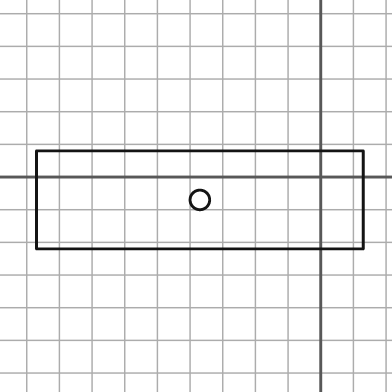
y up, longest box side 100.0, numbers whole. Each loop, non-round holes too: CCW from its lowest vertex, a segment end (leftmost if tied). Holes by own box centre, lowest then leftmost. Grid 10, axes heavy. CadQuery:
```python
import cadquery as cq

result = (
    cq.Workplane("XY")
    .moveTo(-87.0, -22.0)
    .lineTo(13.0, -22.0)
    .lineTo(13.0, 8.0)
    .lineTo(-87.0, 8.0)
    .close()
    .moveTo(-37.0, -7.0)
    .circle(3.0)
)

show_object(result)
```